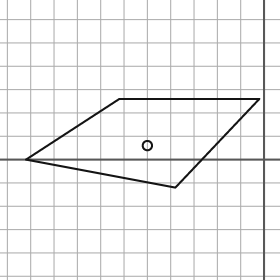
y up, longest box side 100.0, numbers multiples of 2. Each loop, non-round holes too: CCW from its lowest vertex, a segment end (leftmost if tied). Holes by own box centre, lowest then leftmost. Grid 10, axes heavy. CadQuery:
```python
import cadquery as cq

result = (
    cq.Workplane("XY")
    .moveTo(-38.0, -12.0)
    .lineTo(-2.0, 26.0)
    .lineTo(-62.0, 26.0)
    .lineTo(-102.0, 0.0)
    .close()
    .moveTo(-50.0, 6.0)
    .circle(2.0)
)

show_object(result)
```